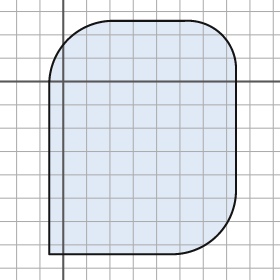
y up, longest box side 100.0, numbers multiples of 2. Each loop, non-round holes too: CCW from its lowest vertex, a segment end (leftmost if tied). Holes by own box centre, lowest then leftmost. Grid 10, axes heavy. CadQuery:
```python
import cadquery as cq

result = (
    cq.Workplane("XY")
    .moveTo(-6.0, -74.0)
    .lineTo(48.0, -74.0)
    .threePointArc((66.0, -66.0), (74.0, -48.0))
    .lineTo(74.0, 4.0)
    .threePointArc((68.0, 20.0), (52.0, 26.0))
    .lineTo(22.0, 26.0)
    .threePointArc((2.0, 18.0), (-6.0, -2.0))
    .close()
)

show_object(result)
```